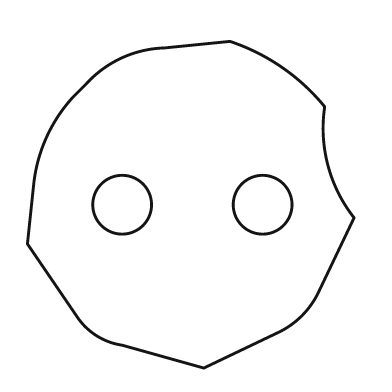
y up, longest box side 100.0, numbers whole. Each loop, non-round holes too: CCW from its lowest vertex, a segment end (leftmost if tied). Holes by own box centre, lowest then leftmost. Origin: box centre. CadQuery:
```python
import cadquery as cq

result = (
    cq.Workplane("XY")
    .moveTo(4.0, -50.0)
    .lineTo(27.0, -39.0)
    .threePointArc((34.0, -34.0), (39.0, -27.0))
    .lineTo(50.0, -4.0)
    .threePointArc((42.0, 12.0), (41.0, 30.0))
    .threePointArc((28.0, 42.0), (12.0, 50.0))
    .lineTo(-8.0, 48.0)
    .threePointArc((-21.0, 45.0), (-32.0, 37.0))
    .lineTo(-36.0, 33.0)
    .threePointArc((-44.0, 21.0), (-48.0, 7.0))
    .lineTo(-50.0, -12.0)
    .lineTo(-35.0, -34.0)
    .threePointArc((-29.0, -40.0), (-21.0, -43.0))
    .close()
    .moveTo(-21.0, 0.0)
    .circle(9.0)
    .moveTo(22.0, 0.0)
    .circle(9.0)
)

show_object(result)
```